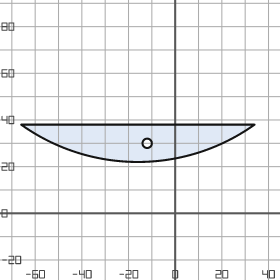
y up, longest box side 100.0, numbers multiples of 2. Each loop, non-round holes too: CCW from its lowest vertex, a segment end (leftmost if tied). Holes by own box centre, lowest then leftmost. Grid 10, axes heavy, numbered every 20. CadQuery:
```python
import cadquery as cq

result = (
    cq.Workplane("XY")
    .moveTo(-66.0, 38.0)
    .threePointArc((-16.0, 22.0), (34.0, 38.0))
    .close()
    .moveTo(-12.0, 30.0)
    .circle(2.0)
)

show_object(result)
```